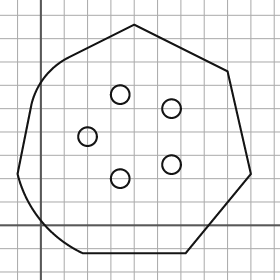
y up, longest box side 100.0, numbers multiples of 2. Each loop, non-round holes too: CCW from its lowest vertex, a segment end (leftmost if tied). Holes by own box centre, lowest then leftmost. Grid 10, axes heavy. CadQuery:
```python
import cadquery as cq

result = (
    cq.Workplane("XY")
    .moveTo(18.0, -12.0)
    .lineTo(62.0, -12.0)
    .lineTo(90.0, 22.0)
    .lineTo(80.0, 66.0)
    .lineTo(40.0, 86.0)
    .lineTo(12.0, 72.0)
    .threePointArc((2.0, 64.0), (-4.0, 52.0))
    .lineTo(-10.0, 22.0)
    .threePointArc((0.0, 2.0), (18.0, -12.0))
    .close()
    .moveTo(34.0, 20.0)
    .circle(4.0)
    .moveTo(56.0, 26.0)
    .circle(4.0)
    .moveTo(20.0, 38.0)
    .circle(4.0)
    .moveTo(56.0, 50.0)
    .circle(4.0)
    .moveTo(34.0, 56.0)
    .circle(4.0)
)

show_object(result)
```